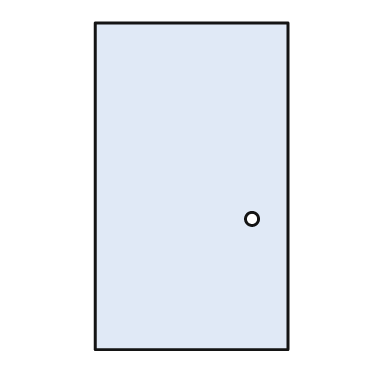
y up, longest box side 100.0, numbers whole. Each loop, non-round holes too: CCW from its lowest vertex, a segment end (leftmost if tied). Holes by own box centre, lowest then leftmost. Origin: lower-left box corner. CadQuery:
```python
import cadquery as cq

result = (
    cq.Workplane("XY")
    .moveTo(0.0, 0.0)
    .lineTo(59.0, 0.0)
    .lineTo(59.0, 100.0)
    .lineTo(0.0, 100.0)
    .close()
    .moveTo(48.0, 40.0)
    .circle(2.0)
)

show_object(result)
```